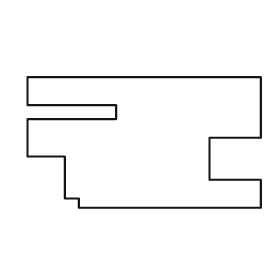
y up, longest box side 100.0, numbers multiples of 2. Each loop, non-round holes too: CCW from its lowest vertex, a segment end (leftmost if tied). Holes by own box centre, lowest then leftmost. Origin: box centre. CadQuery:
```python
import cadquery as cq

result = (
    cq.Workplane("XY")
    .moveTo(-28.0, -28.0)
    .lineTo(50.0, -28.0)
    .lineTo(50.0, -16.0)
    .lineTo(28.0, -16.0)
    .lineTo(28.0, 2.0)
    .lineTo(50.0, 2.0)
    .lineTo(50.0, 28.0)
    .lineTo(-50.0, 28.0)
    .lineTo(-50.0, 16.0)
    .lineTo(-12.0, 16.0)
    .lineTo(-12.0, 10.0)
    .lineTo(-50.0, 10.0)
    .lineTo(-50.0, -6.0)
    .lineTo(-34.0, -6.0)
    .lineTo(-34.0, -24.0)
    .lineTo(-28.0, -24.0)
    .close()
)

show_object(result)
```